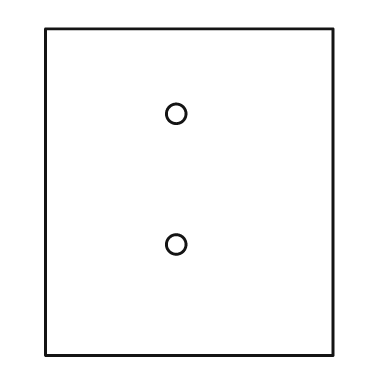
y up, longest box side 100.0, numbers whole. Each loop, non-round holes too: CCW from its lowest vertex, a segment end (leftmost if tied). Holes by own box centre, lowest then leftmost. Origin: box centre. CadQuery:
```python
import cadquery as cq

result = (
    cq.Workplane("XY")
    .moveTo(-44.0, -50.0)
    .lineTo(44.0, -50.0)
    .lineTo(44.0, 50.0)
    .lineTo(-44.0, 50.0)
    .close()
    .moveTo(-4.0, -16.0)
    .circle(3.0)
    .moveTo(-4.0, 24.0)
    .circle(3.0)
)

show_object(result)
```